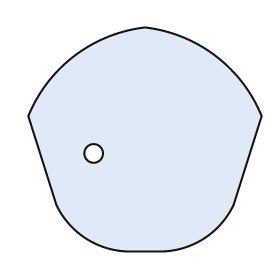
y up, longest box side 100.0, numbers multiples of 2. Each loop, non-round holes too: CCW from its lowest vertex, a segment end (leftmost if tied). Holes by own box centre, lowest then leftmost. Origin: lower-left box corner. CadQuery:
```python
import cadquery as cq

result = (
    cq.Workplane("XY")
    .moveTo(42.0, 0.0)
    .lineTo(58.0, 0.0)
    .threePointArc((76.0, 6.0), (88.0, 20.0))
    .lineTo(100.0, 58.0)
    .threePointArc((80.0, 84.0), (50.0, 96.0))
    .threePointArc((20.0, 84.0), (0.0, 58.0))
    .lineTo(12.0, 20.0)
    .threePointArc((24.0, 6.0), (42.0, 0.0))
    .close()
    .moveTo(28.0, 42.0)
    .circle(4.0)
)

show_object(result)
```